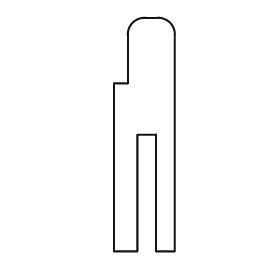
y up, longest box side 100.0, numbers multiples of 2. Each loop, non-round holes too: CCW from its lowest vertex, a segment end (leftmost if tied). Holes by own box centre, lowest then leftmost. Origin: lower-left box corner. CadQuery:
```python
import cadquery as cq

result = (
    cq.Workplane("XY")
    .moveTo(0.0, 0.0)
    .lineTo(10.0, 0.0)
    .lineTo(10.0, 50.0)
    .lineTo(18.0, 50.0)
    .lineTo(18.0, 0.0)
    .lineTo(26.0, 0.0)
    .lineTo(26.0, 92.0)
    .threePointArc((24.0, 98.0), (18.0, 100.0))
    .lineTo(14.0, 100.0)
    .threePointArc((8.0, 98.0), (6.0, 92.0))
    .lineTo(6.0, 72.0)
    .lineTo(0.0, 72.0)
    .close()
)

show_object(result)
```